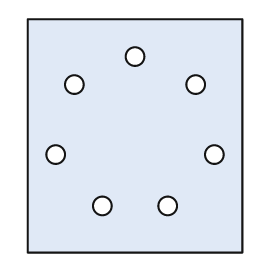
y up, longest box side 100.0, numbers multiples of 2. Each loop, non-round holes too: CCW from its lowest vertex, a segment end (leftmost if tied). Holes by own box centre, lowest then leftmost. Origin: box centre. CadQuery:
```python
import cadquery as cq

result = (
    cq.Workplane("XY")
    .moveTo(-46.0, -50.0)
    .lineTo(46.0, -50.0)
    .lineTo(46.0, 50.0)
    .lineTo(-46.0, 50.0)
    .close()
    .moveTo(-14.0, -30.0)
    .circle(4.0)
    .moveTo(14.0, -30.0)
    .circle(4.0)
    .moveTo(-34.0, -8.0)
    .circle(4.0)
    .moveTo(34.0, -8.0)
    .circle(4.0)
    .moveTo(-26.0, 22.0)
    .circle(4.0)
    .moveTo(26.0, 22.0)
    .circle(4.0)
    .moveTo(0.0, 34.0)
    .circle(4.0)
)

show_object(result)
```